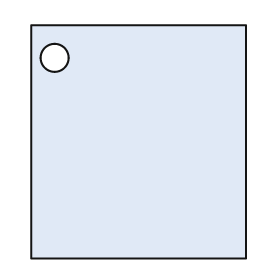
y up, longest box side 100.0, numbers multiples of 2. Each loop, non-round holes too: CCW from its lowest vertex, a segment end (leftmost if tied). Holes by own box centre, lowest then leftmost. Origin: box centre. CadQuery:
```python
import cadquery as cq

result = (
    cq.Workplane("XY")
    .moveTo(-46.0, -50.0)
    .lineTo(46.0, -50.0)
    .lineTo(46.0, 50.0)
    .lineTo(-46.0, 50.0)
    .close()
    .moveTo(-36.0, 36.0)
    .circle(6.0)
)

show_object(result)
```